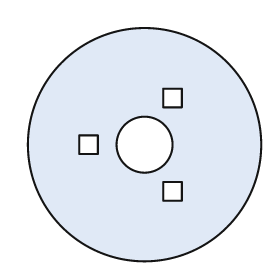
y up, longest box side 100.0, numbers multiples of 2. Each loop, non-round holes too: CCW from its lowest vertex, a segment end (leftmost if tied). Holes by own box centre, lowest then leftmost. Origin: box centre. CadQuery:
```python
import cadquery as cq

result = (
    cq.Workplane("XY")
    .moveTo(0.0, 0.0)
    .circle(50.0)
    .moveTo(8.0, -24.0)
    .lineTo(16.0, -24.0)
    .lineTo(16.0, -16.0)
    .lineTo(8.0, -16.0)
    .close()
    .moveTo(-28.0, -4.0)
    .lineTo(-20.0, -4.0)
    .lineTo(-20.0, 4.0)
    .lineTo(-28.0, 4.0)
    .close()
    .moveTo(0.0, 0.0)
    .circle(12.0)
    .moveTo(8.0, 16.0)
    .lineTo(16.0, 16.0)
    .lineTo(16.0, 24.0)
    .lineTo(8.0, 24.0)
    .close()
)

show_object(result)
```